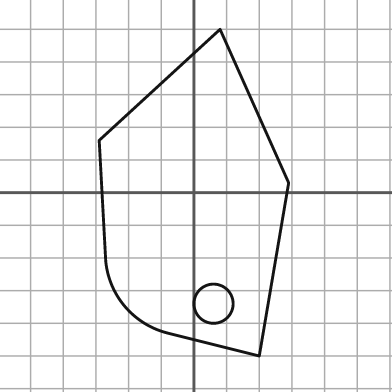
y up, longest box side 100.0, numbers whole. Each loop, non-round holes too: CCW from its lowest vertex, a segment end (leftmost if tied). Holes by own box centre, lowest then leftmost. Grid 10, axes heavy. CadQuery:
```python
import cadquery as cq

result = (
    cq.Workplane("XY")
    .moveTo(20.0, -50.0)
    .lineTo(29.0, 3.0)
    .lineTo(8.0, 50.0)
    .lineTo(-29.0, 16.0)
    .lineTo(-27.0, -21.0)
    .threePointArc((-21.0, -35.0), (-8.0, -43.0))
    .close()
    .moveTo(6.0, -34.0)
    .circle(6.0)
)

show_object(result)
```